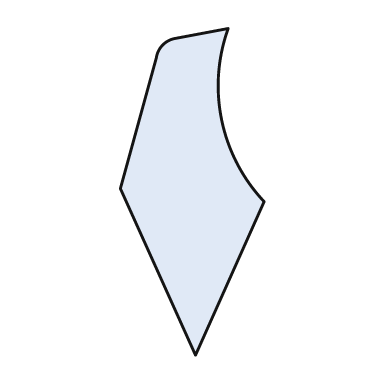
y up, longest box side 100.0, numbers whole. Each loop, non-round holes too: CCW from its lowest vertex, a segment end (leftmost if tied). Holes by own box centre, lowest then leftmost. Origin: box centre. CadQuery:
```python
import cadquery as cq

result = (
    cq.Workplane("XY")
    .moveTo(1.0, -50.0)
    .lineTo(22.0, -3.0)
    .threePointArc((9.0, 22.0), (11.0, 50.0))
    .lineTo(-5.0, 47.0)
    .threePointArc((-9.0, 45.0), (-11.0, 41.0))
    .lineTo(-22.0, 1.0)
    .close()
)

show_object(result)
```